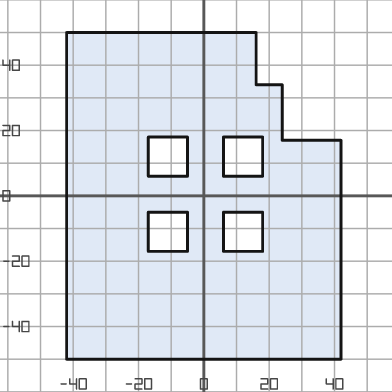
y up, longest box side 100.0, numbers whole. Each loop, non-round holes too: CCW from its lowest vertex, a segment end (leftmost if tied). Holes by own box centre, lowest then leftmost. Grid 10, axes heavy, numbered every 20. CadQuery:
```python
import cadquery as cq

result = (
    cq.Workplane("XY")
    .moveTo(-42.0, -50.0)
    .lineTo(42.0, -50.0)
    .lineTo(42.0, 17.0)
    .lineTo(24.0, 17.0)
    .lineTo(24.0, 34.0)
    .lineTo(16.0, 34.0)
    .lineTo(16.0, 50.0)
    .lineTo(-42.0, 50.0)
    .close()
    .moveTo(-17.0, -17.0)
    .lineTo(-5.0, -17.0)
    .lineTo(-5.0, -5.0)
    .lineTo(-17.0, -5.0)
    .close()
    .moveTo(6.0, -17.0)
    .lineTo(18.0, -17.0)
    .lineTo(18.0, -5.0)
    .lineTo(6.0, -5.0)
    .close()
    .moveTo(-17.0, 6.0)
    .lineTo(-5.0, 6.0)
    .lineTo(-5.0, 18.0)
    .lineTo(-17.0, 18.0)
    .close()
    .moveTo(6.0, 6.0)
    .lineTo(18.0, 6.0)
    .lineTo(18.0, 18.0)
    .lineTo(6.0, 18.0)
    .close()
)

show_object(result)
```